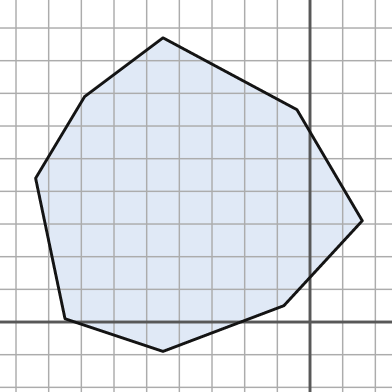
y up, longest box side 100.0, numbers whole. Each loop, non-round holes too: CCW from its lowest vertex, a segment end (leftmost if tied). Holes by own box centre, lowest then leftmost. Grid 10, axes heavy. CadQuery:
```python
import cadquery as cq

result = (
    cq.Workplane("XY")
    .moveTo(-45.0, -9.0)
    .lineTo(-8.0, 5.0)
    .lineTo(16.0, 31.0)
    .lineTo(-4.0, 65.0)
    .lineTo(-45.0, 87.0)
    .lineTo(-69.0, 69.0)
    .lineTo(-84.0, 44.0)
    .lineTo(-75.0, 1.0)
    .close()
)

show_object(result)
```